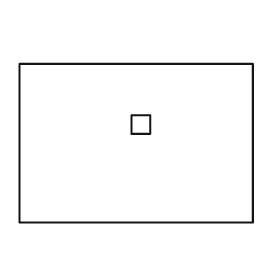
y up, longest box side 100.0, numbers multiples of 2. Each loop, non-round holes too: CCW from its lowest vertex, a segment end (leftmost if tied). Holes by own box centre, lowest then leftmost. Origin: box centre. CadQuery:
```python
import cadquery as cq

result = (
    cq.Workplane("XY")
    .moveTo(-50.0, -34.0)
    .lineTo(50.0, -34.0)
    .lineTo(50.0, 34.0)
    .lineTo(-50.0, 34.0)
    .close()
    .moveTo(-2.0, 4.0)
    .lineTo(6.0, 4.0)
    .lineTo(6.0, 12.0)
    .lineTo(-2.0, 12.0)
    .close()
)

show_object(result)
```